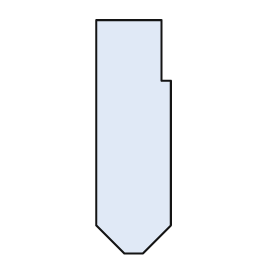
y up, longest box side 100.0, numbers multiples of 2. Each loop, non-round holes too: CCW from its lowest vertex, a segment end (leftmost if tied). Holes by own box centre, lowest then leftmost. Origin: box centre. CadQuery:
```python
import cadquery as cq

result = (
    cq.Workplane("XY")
    .moveTo(-4.0, -50.0)
    .lineTo(4.0, -50.0)
    .lineTo(16.0, -38.0)
    .lineTo(16.0, 24.0)
    .lineTo(12.0, 24.0)
    .lineTo(12.0, 50.0)
    .lineTo(-16.0, 50.0)
    .lineTo(-16.0, -38.0)
    .close()
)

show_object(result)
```